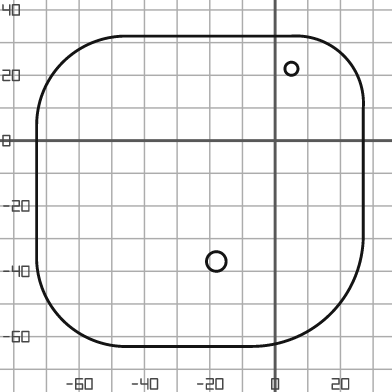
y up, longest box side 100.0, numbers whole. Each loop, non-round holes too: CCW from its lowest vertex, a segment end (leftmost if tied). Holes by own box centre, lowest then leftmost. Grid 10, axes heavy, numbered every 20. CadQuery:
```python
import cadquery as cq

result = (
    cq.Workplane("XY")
    .moveTo(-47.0, -63.0)
    .lineTo(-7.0, -63.0)
    .threePointArc((17.0, -53.0), (27.0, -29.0))
    .lineTo(27.0, 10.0)
    .threePointArc((21.0, 26.0), (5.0, 32.0))
    .lineTo(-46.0, 32.0)
    .threePointArc((-65.0, 24.0), (-73.0, 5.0))
    .lineTo(-73.0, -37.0)
    .threePointArc((-65.0, -55.0), (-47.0, -63.0))
    .close()
    .moveTo(-18.0, -37.0)
    .circle(3.0)
    .moveTo(5.0, 22.0)
    .circle(2.0)
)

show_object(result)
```